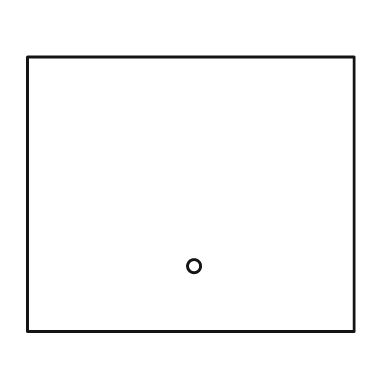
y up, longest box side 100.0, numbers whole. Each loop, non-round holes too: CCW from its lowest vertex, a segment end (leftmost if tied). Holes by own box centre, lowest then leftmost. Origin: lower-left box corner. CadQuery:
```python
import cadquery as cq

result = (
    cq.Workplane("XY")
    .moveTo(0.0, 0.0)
    .lineTo(100.0, 0.0)
    .lineTo(100.0, 84.0)
    .lineTo(0.0, 84.0)
    .close()
    .moveTo(51.0, 20.0)
    .circle(2.0)
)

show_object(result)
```